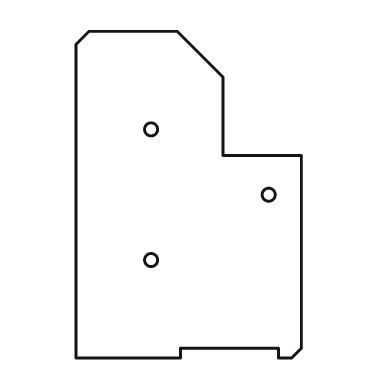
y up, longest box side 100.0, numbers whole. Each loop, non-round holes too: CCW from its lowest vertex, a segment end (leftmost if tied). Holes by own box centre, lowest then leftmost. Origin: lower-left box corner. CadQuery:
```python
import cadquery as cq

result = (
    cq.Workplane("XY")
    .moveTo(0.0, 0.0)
    .lineTo(32.0, 0.0)
    .lineTo(32.0, 3.0)
    .lineTo(62.0, 3.0)
    .lineTo(62.0, 0.0)
    .lineTo(66.0, 0.0)
    .lineTo(69.0, 3.0)
    .lineTo(69.0, 62.0)
    .lineTo(45.0, 62.0)
    .lineTo(45.0, 86.0)
    .lineTo(31.0, 100.0)
    .lineTo(4.0, 100.0)
    .lineTo(0.0, 96.0)
    .close()
    .moveTo(23.0, 30.0)
    .circle(2.0)
    .moveTo(59.0, 50.0)
    .circle(2.0)
    .moveTo(23.0, 70.0)
    .circle(2.0)
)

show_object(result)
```